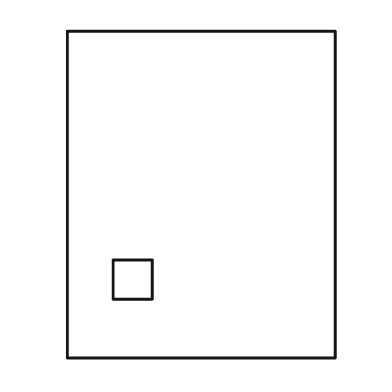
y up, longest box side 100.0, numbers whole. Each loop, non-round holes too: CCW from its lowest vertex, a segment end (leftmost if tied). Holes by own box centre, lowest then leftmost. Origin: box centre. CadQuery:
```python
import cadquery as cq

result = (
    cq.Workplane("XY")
    .moveTo(-41.0, -50.0)
    .lineTo(41.0, -50.0)
    .lineTo(41.0, 50.0)
    .lineTo(-41.0, 50.0)
    .close()
    .moveTo(-27.0, -32.0)
    .lineTo(-15.0, -32.0)
    .lineTo(-15.0, -20.0)
    .lineTo(-27.0, -20.0)
    .close()
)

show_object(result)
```